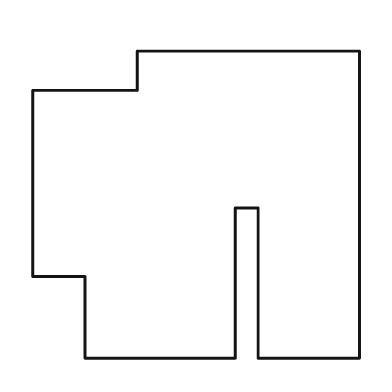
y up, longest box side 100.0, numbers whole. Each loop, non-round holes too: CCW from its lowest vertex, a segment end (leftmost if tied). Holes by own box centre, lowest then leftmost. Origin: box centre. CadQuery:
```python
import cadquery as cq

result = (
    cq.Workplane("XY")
    .moveTo(-34.0, -47.0)
    .lineTo(12.0, -47.0)
    .lineTo(12.0, -1.0)
    .lineTo(19.0, -1.0)
    .lineTo(19.0, -47.0)
    .lineTo(50.0, -47.0)
    .lineTo(50.0, 47.0)
    .lineTo(-18.0, 47.0)
    .lineTo(-18.0, 35.0)
    .lineTo(-50.0, 35.0)
    .lineTo(-50.0, -22.0)
    .lineTo(-34.0, -22.0)
    .close()
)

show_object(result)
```